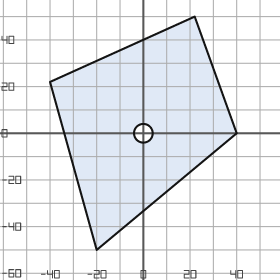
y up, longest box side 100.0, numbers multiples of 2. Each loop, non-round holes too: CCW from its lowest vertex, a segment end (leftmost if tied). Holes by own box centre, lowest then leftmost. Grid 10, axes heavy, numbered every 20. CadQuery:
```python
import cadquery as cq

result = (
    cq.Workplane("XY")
    .moveTo(-20.0, -50.0)
    .lineTo(40.0, 0.0)
    .lineTo(22.0, 50.0)
    .lineTo(-40.0, 22.0)
    .close()
    .moveTo(0.0, 0.0)
    .circle(4.0)
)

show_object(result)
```